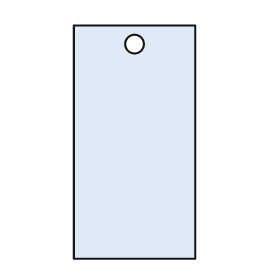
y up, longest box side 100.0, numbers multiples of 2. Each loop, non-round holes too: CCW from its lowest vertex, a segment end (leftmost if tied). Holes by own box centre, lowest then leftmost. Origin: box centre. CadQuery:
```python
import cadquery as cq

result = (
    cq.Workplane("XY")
    .moveTo(-26.0, -50.0)
    .lineTo(26.0, -50.0)
    .lineTo(26.0, 50.0)
    .lineTo(-26.0, 50.0)
    .close()
    .moveTo(0.0, 42.0)
    .circle(4.0)
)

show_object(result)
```